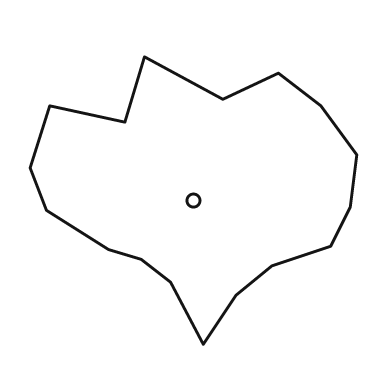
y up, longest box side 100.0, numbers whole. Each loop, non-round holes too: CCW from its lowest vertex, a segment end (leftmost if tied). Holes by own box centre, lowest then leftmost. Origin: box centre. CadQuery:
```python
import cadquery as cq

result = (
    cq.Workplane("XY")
    .moveTo(3.0, -44.0)
    .lineTo(13.0, -29.0)
    .lineTo(24.0, -20.0)
    .lineTo(42.0, -14.0)
    .lineTo(48.0, -2.0)
    .lineTo(50.0, 14.0)
    .lineTo(39.0, 29.0)
    .lineTo(26.0, 39.0)
    .lineTo(9.0, 31.0)
    .lineTo(-15.0, 44.0)
    .lineTo(-21.0, 24.0)
    .lineTo(-44.0, 29.0)
    .lineTo(-50.0, 10.0)
    .lineTo(-45.0, -3.0)
    .lineTo(-26.0, -15.0)
    .lineTo(-16.0, -18.0)
    .lineTo(-7.0, -25.0)
    .close()
    .moveTo(0.0, 0.0)
    .circle(2.0)
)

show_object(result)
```